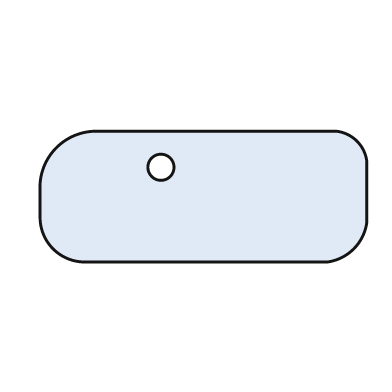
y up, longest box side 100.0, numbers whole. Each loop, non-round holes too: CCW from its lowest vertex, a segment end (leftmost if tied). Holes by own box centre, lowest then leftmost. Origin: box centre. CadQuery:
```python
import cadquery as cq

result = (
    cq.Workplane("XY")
    .moveTo(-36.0, -20.0)
    .lineTo(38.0, -20.0)
    .threePointArc((46.0, -16.0), (50.0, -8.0))
    .lineTo(50.0, 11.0)
    .threePointArc((47.0, 17.0), (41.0, 20.0))
    .lineTo(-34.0, 20.0)
    .threePointArc((-45.0, 15.0), (-50.0, 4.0))
    .lineTo(-50.0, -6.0)
    .threePointArc((-46.0, -16.0), (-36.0, -20.0))
    .close()
    .moveTo(-13.0, 9.0)
    .circle(4.0)
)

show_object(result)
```